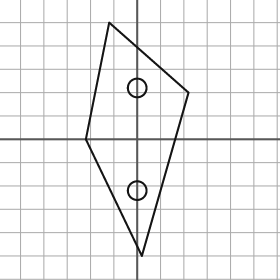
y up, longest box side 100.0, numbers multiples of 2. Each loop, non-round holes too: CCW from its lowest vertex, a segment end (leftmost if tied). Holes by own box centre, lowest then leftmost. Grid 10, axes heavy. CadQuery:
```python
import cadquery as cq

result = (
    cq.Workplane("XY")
    .moveTo(2.0, -50.0)
    .lineTo(22.0, 20.0)
    .lineTo(-12.0, 50.0)
    .lineTo(-22.0, 0.0)
    .close()
    .moveTo(0.0, -22.0)
    .circle(4.0)
    .moveTo(0.0, 22.0)
    .circle(4.0)
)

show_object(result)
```